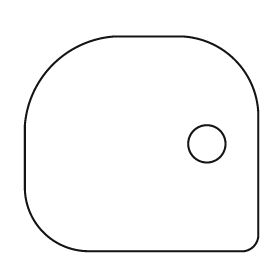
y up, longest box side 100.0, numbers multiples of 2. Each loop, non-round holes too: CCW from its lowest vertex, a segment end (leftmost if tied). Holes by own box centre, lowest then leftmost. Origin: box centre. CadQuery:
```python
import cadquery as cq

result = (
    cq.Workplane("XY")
    .moveTo(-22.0, -46.0)
    .lineTo(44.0, -46.0)
    .threePointArc((48.0, -44.0), (50.0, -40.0))
    .lineTo(50.0, 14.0)
    .threePointArc((40.0, 36.0), (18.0, 46.0))
    .lineTo(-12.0, 46.0)
    .threePointArc((-38.0, 34.0), (-50.0, 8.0))
    .lineTo(-50.0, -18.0)
    .threePointArc((-42.0, -38.0), (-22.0, -46.0))
    .close()
    .moveTo(28.0, 0.0)
    .circle(8.0)
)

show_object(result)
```